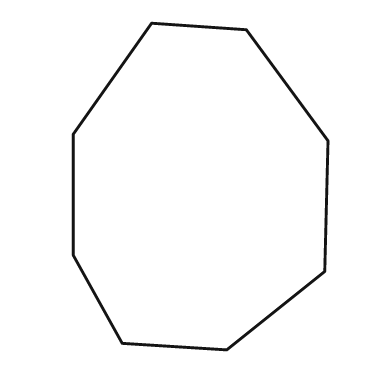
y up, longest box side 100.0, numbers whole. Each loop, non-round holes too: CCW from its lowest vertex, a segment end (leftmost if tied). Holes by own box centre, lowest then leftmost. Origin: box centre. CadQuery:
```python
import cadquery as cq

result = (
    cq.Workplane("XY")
    .moveTo(8.0, -50.0)
    .lineTo(38.0, -26.0)
    .lineTo(39.0, 14.0)
    .lineTo(14.0, 48.0)
    .lineTo(-15.0, 50.0)
    .lineTo(-39.0, 16.0)
    .lineTo(-39.0, -21.0)
    .lineTo(-24.0, -48.0)
    .close()
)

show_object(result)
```